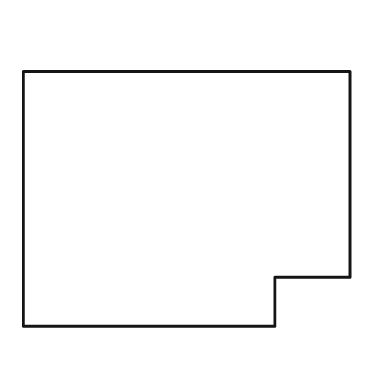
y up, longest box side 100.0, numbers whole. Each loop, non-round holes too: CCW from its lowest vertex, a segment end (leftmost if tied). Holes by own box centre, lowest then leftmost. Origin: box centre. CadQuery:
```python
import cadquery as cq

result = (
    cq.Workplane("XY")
    .moveTo(-50.0, -39.0)
    .lineTo(27.0, -39.0)
    .lineTo(27.0, -24.0)
    .lineTo(50.0, -24.0)
    .lineTo(50.0, 39.0)
    .lineTo(-50.0, 39.0)
    .close()
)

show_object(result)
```